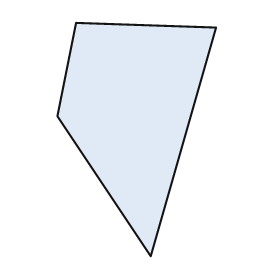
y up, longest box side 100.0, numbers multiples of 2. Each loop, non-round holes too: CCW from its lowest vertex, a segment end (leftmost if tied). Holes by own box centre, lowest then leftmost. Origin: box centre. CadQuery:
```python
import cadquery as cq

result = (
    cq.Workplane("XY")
    .moveTo(6.0, -50.0)
    .lineTo(34.0, 48.0)
    .lineTo(-26.0, 50.0)
    .lineTo(-34.0, 10.0)
    .close()
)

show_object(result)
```